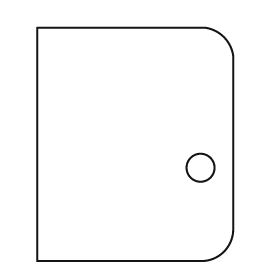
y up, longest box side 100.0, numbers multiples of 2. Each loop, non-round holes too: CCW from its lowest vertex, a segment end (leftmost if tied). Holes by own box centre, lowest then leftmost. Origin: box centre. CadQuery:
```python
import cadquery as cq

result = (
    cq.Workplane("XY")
    .moveTo(-42.0, -50.0)
    .lineTo(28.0, -50.0)
    .threePointArc((38.0, -46.0), (42.0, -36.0))
    .lineTo(42.0, 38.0)
    .threePointArc((38.0, 46.0), (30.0, 50.0))
    .lineTo(-42.0, 50.0)
    .close()
    .moveTo(28.0, -10.0)
    .circle(6.0)
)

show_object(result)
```